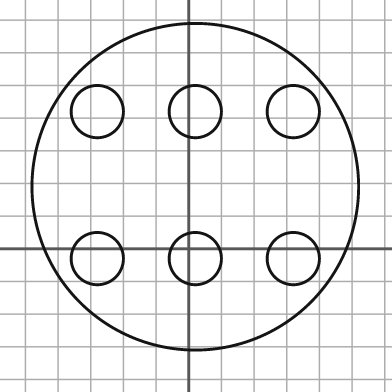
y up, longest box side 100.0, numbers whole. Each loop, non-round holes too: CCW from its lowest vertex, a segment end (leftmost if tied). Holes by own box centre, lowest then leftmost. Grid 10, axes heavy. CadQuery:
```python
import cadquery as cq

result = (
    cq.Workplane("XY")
    .moveTo(2.0, 19.0)
    .circle(50.0)
    .moveTo(-28.0, -3.0)
    .circle(8.0)
    .moveTo(2.0, -3.0)
    .circle(8.0)
    .moveTo(32.0, -3.0)
    .circle(8.0)
    .moveTo(-28.0, 42.0)
    .circle(8.0)
    .moveTo(2.0, 42.0)
    .circle(8.0)
    .moveTo(32.0, 42.0)
    .circle(8.0)
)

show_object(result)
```